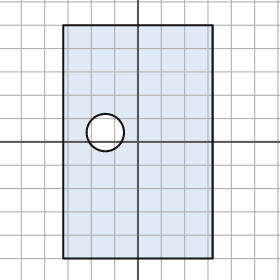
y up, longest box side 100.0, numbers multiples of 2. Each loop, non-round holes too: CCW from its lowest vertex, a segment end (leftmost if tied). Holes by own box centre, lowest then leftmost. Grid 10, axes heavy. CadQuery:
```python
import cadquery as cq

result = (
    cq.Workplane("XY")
    .moveTo(-32.0, -50.0)
    .lineTo(32.0, -50.0)
    .lineTo(32.0, 50.0)
    .lineTo(-32.0, 50.0)
    .close()
    .moveTo(-14.0, 4.0)
    .circle(8.0)
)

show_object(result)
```